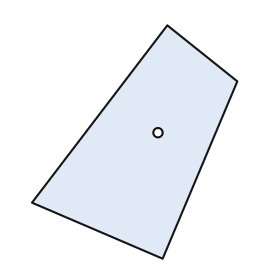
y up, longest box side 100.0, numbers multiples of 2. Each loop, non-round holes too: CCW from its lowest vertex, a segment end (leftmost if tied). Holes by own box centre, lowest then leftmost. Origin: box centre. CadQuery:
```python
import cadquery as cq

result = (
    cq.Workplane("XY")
    .moveTo(12.0, -50.0)
    .lineTo(44.0, 26.0)
    .lineTo(14.0, 50.0)
    .lineTo(-44.0, -26.0)
    .close()
    .moveTo(10.0, 4.0)
    .circle(2.0)
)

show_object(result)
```